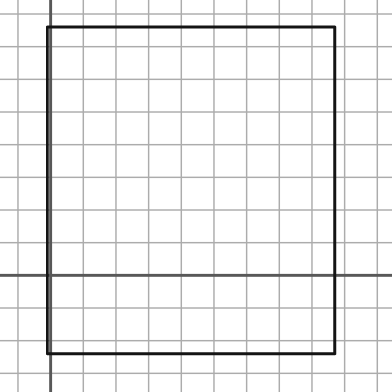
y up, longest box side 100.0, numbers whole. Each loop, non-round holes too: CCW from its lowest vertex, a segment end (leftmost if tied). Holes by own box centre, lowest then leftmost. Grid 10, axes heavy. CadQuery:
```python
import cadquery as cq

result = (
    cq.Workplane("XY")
    .moveTo(-1.0, -24.0)
    .lineTo(87.0, -24.0)
    .lineTo(87.0, 76.0)
    .lineTo(-1.0, 76.0)
    .close()
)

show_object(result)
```